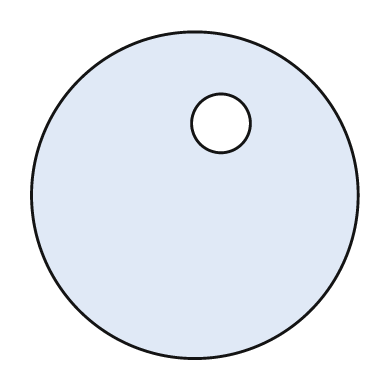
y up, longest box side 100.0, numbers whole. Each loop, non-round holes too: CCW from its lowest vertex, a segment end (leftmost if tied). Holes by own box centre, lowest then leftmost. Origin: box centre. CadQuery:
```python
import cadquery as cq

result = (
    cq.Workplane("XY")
    .moveTo(0.0, 0.0)
    .circle(50.0)
    .moveTo(8.0, 22.0)
    .circle(9.0)
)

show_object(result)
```